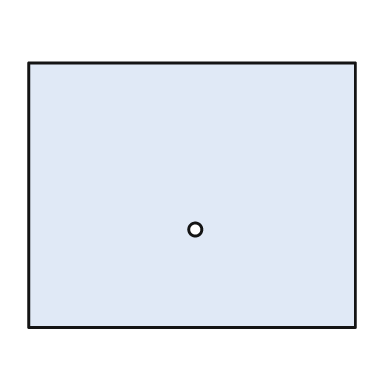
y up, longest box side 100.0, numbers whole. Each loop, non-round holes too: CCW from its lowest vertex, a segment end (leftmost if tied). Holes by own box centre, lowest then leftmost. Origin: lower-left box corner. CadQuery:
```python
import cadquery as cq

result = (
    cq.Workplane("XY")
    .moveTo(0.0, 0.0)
    .lineTo(100.0, 0.0)
    .lineTo(100.0, 81.0)
    .lineTo(0.0, 81.0)
    .close()
    .moveTo(51.0, 30.0)
    .circle(2.0)
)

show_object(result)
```